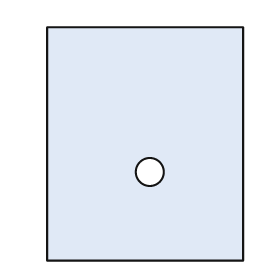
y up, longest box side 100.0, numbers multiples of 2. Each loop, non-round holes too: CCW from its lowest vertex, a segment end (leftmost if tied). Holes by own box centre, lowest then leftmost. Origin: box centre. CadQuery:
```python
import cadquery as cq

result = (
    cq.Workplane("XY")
    .moveTo(-42.0, -50.0)
    .lineTo(42.0, -50.0)
    .lineTo(42.0, 50.0)
    .lineTo(-42.0, 50.0)
    .close()
    .moveTo(2.0, -12.0)
    .circle(6.0)
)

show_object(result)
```